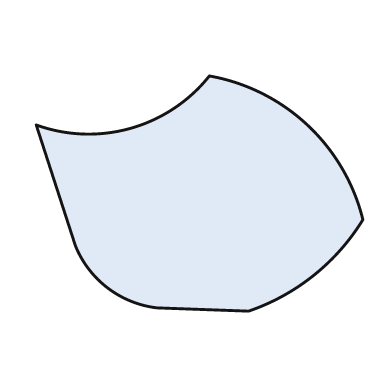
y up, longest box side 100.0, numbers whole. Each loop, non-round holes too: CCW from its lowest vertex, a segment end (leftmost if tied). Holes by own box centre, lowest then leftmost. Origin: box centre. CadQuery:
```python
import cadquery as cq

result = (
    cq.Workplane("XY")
    .moveTo(15.0, -36.0)
    .threePointArc((35.0, -25.0), (50.0, -8.0))
    .threePointArc((33.0, 21.0), (3.0, 36.0))
    .threePointArc((-21.0, 20.0), (-50.0, 21.0))
    .lineTo(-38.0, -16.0)
    .threePointArc((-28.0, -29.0), (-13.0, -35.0))
    .close()
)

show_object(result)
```